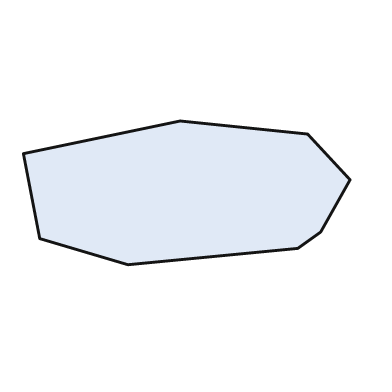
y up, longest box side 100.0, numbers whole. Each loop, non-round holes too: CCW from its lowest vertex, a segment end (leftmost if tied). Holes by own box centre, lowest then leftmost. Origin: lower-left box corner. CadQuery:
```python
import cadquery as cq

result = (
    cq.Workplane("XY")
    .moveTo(32.0, 0.0)
    .lineTo(84.0, 5.0)
    .lineTo(91.0, 10.0)
    .lineTo(100.0, 26.0)
    .lineTo(87.0, 40.0)
    .lineTo(48.0, 44.0)
    .lineTo(0.0, 34.0)
    .lineTo(5.0, 8.0)
    .close()
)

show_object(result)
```